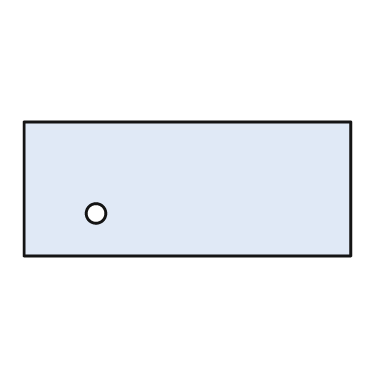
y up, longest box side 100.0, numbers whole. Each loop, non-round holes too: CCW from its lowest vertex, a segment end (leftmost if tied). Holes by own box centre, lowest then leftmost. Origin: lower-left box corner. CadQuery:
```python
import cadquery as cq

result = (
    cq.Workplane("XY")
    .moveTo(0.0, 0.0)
    .lineTo(100.0, 0.0)
    .lineTo(100.0, 41.0)
    .lineTo(0.0, 41.0)
    .close()
    .moveTo(22.0, 13.0)
    .circle(3.0)
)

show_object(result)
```